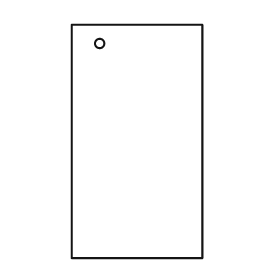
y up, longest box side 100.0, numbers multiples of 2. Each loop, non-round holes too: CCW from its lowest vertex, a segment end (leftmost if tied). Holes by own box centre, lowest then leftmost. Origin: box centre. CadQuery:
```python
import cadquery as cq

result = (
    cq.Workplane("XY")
    .moveTo(-28.0, -50.0)
    .lineTo(28.0, -50.0)
    .lineTo(28.0, 50.0)
    .lineTo(-28.0, 50.0)
    .close()
    .moveTo(-16.0, 42.0)
    .circle(2.0)
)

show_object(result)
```